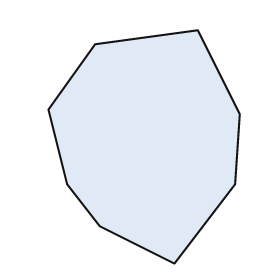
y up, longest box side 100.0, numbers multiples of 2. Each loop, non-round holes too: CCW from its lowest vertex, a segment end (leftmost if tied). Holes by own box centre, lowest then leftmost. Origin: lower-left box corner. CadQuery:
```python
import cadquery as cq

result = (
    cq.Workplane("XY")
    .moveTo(54.0, 0.0)
    .lineTo(80.0, 34.0)
    .lineTo(82.0, 64.0)
    .lineTo(64.0, 100.0)
    .lineTo(20.0, 94.0)
    .lineTo(0.0, 66.0)
    .lineTo(8.0, 34.0)
    .lineTo(22.0, 16.0)
    .close()
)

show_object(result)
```